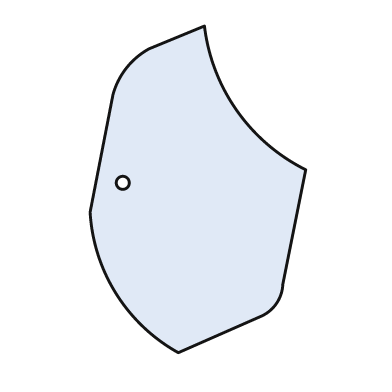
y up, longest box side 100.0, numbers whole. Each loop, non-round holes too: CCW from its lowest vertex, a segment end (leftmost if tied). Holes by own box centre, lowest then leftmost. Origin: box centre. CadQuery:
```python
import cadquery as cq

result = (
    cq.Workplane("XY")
    .moveTo(-6.0, -50.0)
    .lineTo(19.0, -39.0)
    .threePointArc((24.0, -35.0), (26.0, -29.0))
    .lineTo(33.0, 6.0)
    .threePointArc((12.0, 24.0), (2.0, 50.0))
    .lineTo(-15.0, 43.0)
    .threePointArc((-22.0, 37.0), (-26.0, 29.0))
    .lineTo(-33.0, -7.0)
    .threePointArc((-25.0, -32.0), (-6.0, -50.0))
    .close()
    .moveTo(-23.0, 2.0)
    .circle(2.0)
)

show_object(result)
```